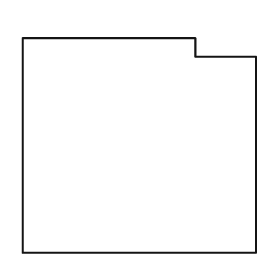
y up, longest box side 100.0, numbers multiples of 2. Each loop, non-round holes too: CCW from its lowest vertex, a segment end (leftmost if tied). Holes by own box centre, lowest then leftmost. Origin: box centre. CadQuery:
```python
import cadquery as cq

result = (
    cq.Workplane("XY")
    .moveTo(-50.0, -46.0)
    .lineTo(50.0, -46.0)
    .lineTo(50.0, 38.0)
    .lineTo(24.0, 38.0)
    .lineTo(24.0, 46.0)
    .lineTo(-50.0, 46.0)
    .close()
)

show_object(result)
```